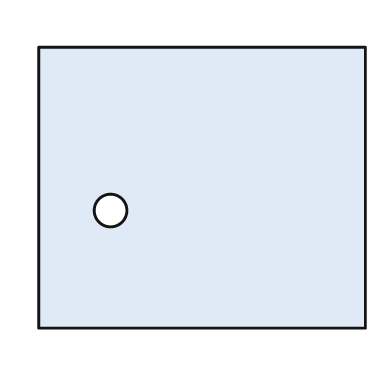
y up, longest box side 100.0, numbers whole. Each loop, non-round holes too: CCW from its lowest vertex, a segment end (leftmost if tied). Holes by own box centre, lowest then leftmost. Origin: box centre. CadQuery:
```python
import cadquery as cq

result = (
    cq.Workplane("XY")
    .moveTo(-50.0, -43.0)
    .lineTo(50.0, -43.0)
    .lineTo(50.0, 43.0)
    .lineTo(-50.0, 43.0)
    .close()
    .moveTo(-28.0, -7.0)
    .circle(5.0)
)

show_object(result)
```